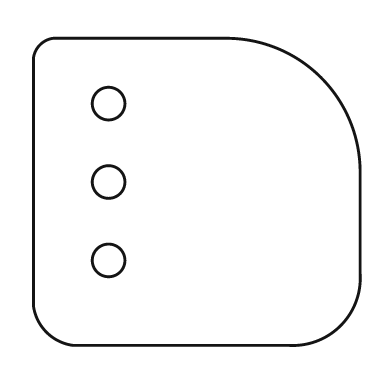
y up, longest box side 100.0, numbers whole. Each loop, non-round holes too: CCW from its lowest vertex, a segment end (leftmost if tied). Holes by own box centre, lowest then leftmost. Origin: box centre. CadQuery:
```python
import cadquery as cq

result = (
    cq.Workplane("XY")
    .moveTo(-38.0, -47.0)
    .lineTo(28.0, -47.0)
    .threePointArc((44.0, -41.0), (50.0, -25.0))
    .lineTo(50.0, 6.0)
    .threePointArc((38.0, 35.0), (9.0, 47.0))
    .lineTo(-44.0, 47.0)
    .threePointArc((-48.0, 45.0), (-50.0, 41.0))
    .lineTo(-50.0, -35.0)
    .threePointArc((-46.0, -43.0), (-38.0, -47.0))
    .close()
    .moveTo(-27.0, -21.0)
    .circle(5.0)
    .moveTo(-27.0, 3.0)
    .circle(5.0)
    .moveTo(-27.0, 27.0)
    .circle(5.0)
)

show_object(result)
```